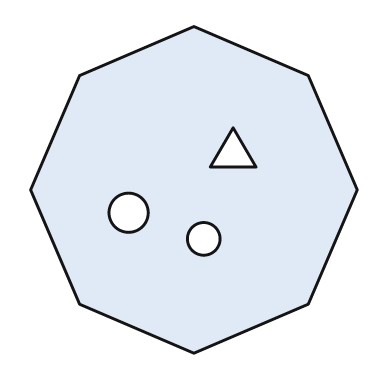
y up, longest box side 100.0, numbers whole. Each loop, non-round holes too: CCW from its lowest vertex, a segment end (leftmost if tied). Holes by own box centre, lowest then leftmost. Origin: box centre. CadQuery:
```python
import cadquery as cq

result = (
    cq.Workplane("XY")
    .moveTo(0.0, -50.0)
    .lineTo(35.0, -35.0)
    .lineTo(50.0, 0.0)
    .lineTo(35.0, 35.0)
    .lineTo(0.0, 50.0)
    .lineTo(-35.0, 35.0)
    .lineTo(-50.0, 0.0)
    .lineTo(-35.0, -35.0)
    .close()
    .moveTo(3.0, -15.0)
    .circle(5.0)
    .moveTo(-20.0, -7.0)
    .circle(6.0)
    .moveTo(5.0, 7.0)
    .lineTo(19.0, 7.0)
    .lineTo(12.0, 19.0)
    .close()
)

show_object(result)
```